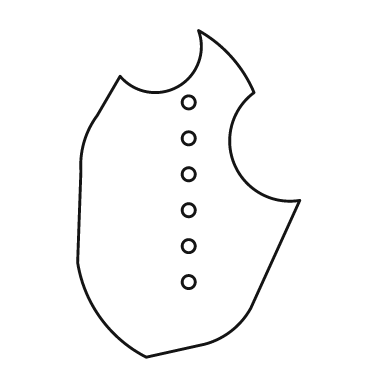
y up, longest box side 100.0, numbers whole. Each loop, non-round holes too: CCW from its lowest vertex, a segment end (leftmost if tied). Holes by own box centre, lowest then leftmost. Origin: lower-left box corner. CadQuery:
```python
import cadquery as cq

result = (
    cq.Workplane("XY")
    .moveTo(21.0, 0.0)
    .lineTo(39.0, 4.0)
    .threePointArc((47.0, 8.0), (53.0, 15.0))
    .lineTo(68.0, 48.0)
    .threePointArc((48.0, 59.0), (54.0, 81.0))
    .threePointArc((47.0, 92.0), (37.0, 100.0))
    .threePointArc((31.0, 83.0), (13.0, 86.0))
    .lineTo(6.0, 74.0)
    .threePointArc((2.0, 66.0), (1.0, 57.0))
    .lineTo(0.0, 29.0)
    .threePointArc((7.0, 12.0), (21.0, 0.0))
    .close()
    .moveTo(34.0, 23.0)
    .circle(2.0)
    .moveTo(34.0, 34.0)
    .circle(2.0)
    .moveTo(34.0, 45.0)
    .circle(2.0)
    .moveTo(34.0, 56.0)
    .circle(2.0)
    .moveTo(34.0, 67.0)
    .circle(2.0)
    .moveTo(34.0, 78.0)
    .circle(2.0)
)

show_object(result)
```